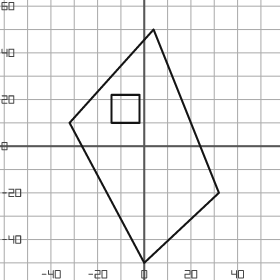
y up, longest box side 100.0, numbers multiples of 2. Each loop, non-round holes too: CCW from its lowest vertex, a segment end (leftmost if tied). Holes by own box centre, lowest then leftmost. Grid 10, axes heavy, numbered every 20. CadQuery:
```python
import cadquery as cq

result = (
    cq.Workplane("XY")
    .moveTo(0.0, -50.0)
    .lineTo(32.0, -20.0)
    .lineTo(4.0, 50.0)
    .lineTo(-32.0, 10.0)
    .close()
    .moveTo(-14.0, 10.0)
    .lineTo(-2.0, 10.0)
    .lineTo(-2.0, 22.0)
    .lineTo(-14.0, 22.0)
    .close()
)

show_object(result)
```